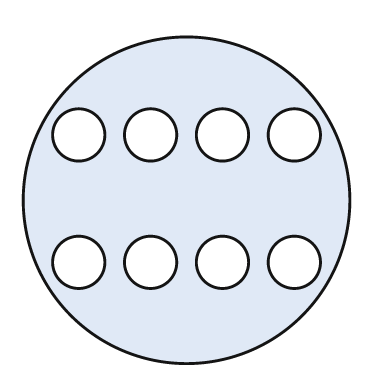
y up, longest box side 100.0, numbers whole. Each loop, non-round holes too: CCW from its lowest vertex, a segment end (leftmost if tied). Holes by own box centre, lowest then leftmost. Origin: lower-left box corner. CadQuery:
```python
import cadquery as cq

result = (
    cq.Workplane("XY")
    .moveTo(50.0, 50.0)
    .circle(50.0)
    .moveTo(17.0, 31.0)
    .circle(8.0)
    .moveTo(39.0, 31.0)
    .circle(8.0)
    .moveTo(61.0, 31.0)
    .circle(8.0)
    .moveTo(83.0, 31.0)
    .circle(8.0)
    .moveTo(17.0, 70.0)
    .circle(8.0)
    .moveTo(39.0, 70.0)
    .circle(8.0)
    .moveTo(61.0, 70.0)
    .circle(8.0)
    .moveTo(83.0, 70.0)
    .circle(8.0)
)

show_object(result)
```